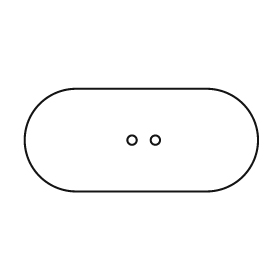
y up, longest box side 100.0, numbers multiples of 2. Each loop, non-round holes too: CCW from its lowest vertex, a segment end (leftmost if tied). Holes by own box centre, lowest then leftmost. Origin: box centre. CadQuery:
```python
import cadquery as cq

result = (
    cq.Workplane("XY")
    .moveTo(-28.0, -22.0)
    .lineTo(28.0, -22.0)
    .threePointArc((50.0, 0.0), (28.0, 22.0))
    .lineTo(-28.0, 22.0)
    .threePointArc((-50.0, 0.0), (-28.0, -22.0))
    .close()
    .moveTo(-4.0, 0.0)
    .circle(2.0)
    .moveTo(6.0, 0.0)
    .circle(2.0)
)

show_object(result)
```